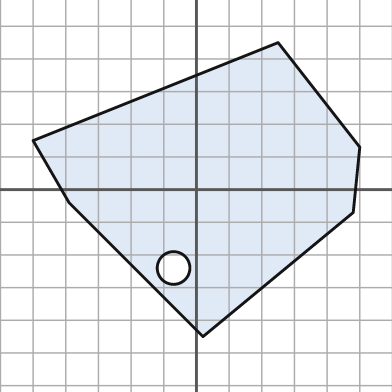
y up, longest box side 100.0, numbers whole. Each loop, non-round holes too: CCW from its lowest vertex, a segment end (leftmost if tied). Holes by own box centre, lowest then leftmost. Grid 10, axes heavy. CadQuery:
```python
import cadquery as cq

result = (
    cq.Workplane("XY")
    .moveTo(2.0, -45.0)
    .lineTo(48.0, -7.0)
    .lineTo(50.0, 13.0)
    .lineTo(25.0, 45.0)
    .lineTo(-50.0, 15.0)
    .lineTo(-39.0, -4.0)
    .close()
    .moveTo(-7.0, -24.0)
    .circle(5.0)
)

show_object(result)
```